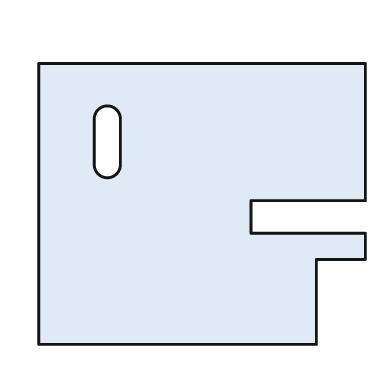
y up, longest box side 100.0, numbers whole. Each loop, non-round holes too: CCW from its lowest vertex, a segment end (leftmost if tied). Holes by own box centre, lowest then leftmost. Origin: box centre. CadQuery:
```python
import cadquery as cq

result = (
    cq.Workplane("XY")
    .moveTo(-50.0, -43.0)
    .lineTo(35.0, -43.0)
    .lineTo(35.0, -17.0)
    .lineTo(50.0, -17.0)
    .lineTo(50.0, -9.0)
    .lineTo(15.0, -9.0)
    .lineTo(15.0, 1.0)
    .lineTo(50.0, 1.0)
    .lineTo(50.0, 43.0)
    .lineTo(-50.0, 43.0)
    .close()
    .moveTo(-33.0, 12.0)
    .threePointArc((-29.0, 8.0), (-25.0, 12.0))
    .lineTo(-25.0, 26.0)
    .threePointArc((-29.0, 30.0), (-33.0, 26.0))
    .close()
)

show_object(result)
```